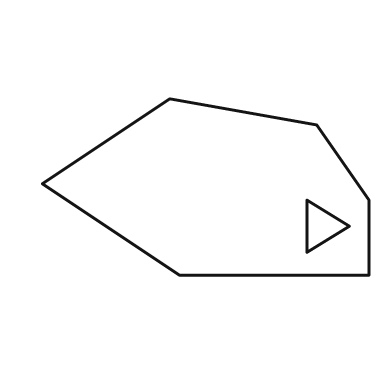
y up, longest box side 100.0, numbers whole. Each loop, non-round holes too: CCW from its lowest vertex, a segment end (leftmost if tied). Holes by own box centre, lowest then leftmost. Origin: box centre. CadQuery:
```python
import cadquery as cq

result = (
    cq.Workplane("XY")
    .moveTo(-8.0, -27.0)
    .lineTo(50.0, -27.0)
    .lineTo(50.0, -4.0)
    .lineTo(34.0, 19.0)
    .lineTo(-11.0, 27.0)
    .lineTo(-50.0, 1.0)
    .close()
    .moveTo(31.0, -20.0)
    .lineTo(44.0, -12.0)
    .lineTo(31.0, -4.0)
    .close()
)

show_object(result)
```